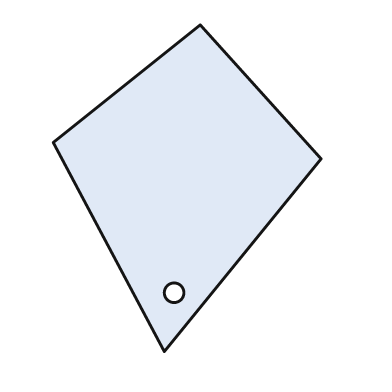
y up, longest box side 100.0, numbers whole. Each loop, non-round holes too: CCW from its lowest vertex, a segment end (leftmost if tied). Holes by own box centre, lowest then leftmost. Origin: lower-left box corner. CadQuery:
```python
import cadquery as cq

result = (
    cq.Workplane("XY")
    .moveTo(34.0, 0.0)
    .lineTo(82.0, 59.0)
    .lineTo(45.0, 100.0)
    .lineTo(0.0, 64.0)
    .close()
    .moveTo(37.0, 18.0)
    .circle(3.0)
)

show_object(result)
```